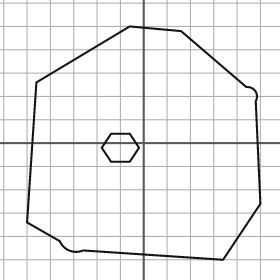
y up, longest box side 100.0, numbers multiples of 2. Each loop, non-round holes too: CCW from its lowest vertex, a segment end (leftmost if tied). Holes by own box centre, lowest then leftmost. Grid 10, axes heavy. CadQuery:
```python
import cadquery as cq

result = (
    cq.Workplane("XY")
    .moveTo(34.0, -50.0)
    .lineTo(50.0, -26.0)
    .lineTo(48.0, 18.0)
    .threePointArc((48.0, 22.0), (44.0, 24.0))
    .lineTo(16.0, 48.0)
    .lineTo(-6.0, 50.0)
    .lineTo(-46.0, 26.0)
    .lineTo(-50.0, -34.0)
    .lineTo(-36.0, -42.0)
    .threePointArc((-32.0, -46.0), (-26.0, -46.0))
    .close()
    .moveTo(-14.0, -8.0)
    .lineTo(-6.0, -8.0)
    .lineTo(-2.0, -2.0)
    .lineTo(-6.0, 4.0)
    .lineTo(-14.0, 4.0)
    .lineTo(-18.0, -2.0)
    .close()
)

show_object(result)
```